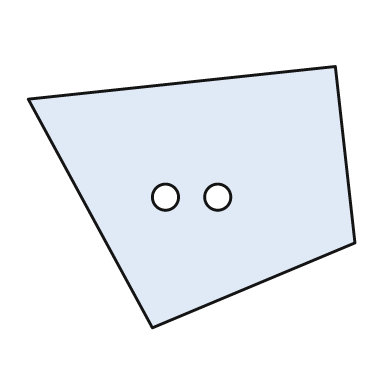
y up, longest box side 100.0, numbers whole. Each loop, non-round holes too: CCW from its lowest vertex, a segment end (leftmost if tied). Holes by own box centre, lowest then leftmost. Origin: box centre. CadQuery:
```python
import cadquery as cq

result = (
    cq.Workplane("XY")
    .moveTo(-12.0, -40.0)
    .lineTo(50.0, -14.0)
    .lineTo(44.0, 40.0)
    .lineTo(-50.0, 30.0)
    .close()
    .moveTo(-8.0, 0.0)
    .circle(4.0)
    .moveTo(8.0, 0.0)
    .circle(4.0)
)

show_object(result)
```